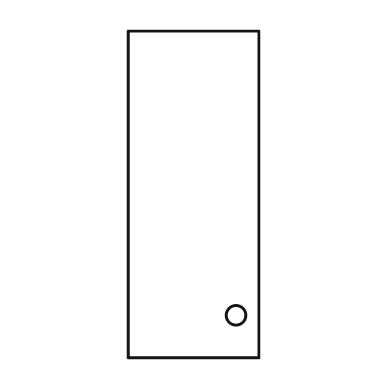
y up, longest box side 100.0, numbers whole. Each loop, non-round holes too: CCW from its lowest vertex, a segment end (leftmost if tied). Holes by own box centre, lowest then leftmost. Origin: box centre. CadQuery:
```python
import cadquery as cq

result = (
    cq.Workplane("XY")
    .moveTo(-20.0, -50.0)
    .lineTo(20.0, -50.0)
    .lineTo(20.0, 50.0)
    .lineTo(-20.0, 50.0)
    .close()
    .moveTo(13.0, -37.0)
    .circle(3.0)
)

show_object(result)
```